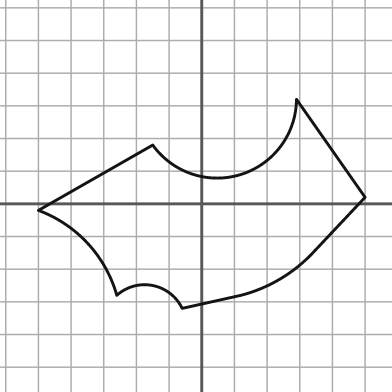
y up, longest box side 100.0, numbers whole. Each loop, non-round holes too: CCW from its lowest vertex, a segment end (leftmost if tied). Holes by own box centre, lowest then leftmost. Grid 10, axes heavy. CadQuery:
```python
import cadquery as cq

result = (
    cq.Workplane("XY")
    .moveTo(-6.0, -32.0)
    .lineTo(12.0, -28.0)
    .threePointArc((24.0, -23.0), (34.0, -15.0))
    .lineTo(50.0, 2.0)
    .lineTo(29.0, 32.0)
    .threePointArc((12.0, 9.0), (-15.0, 18.0))
    .lineTo(-50.0, -2.0)
    .threePointArc((-35.0, -12.0), (-26.0, -28.0))
    .threePointArc((-15.0, -25.0), (-6.0, -32.0))
    .close()
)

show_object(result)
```